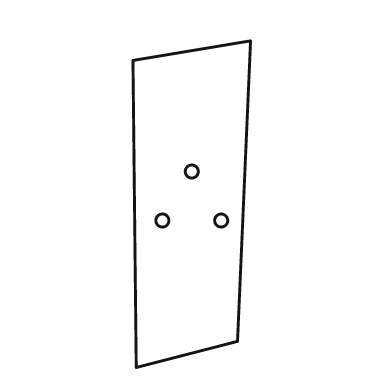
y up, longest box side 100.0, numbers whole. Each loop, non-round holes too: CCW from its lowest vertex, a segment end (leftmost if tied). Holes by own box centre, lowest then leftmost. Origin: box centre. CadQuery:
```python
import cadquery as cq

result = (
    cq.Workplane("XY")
    .moveTo(-17.0, -50.0)
    .lineTo(14.0, -42.0)
    .lineTo(18.0, 50.0)
    .lineTo(-18.0, 44.0)
    .close()
    .moveTo(-9.0, -5.0)
    .circle(2.0)
    .moveTo(9.0, -5.0)
    .circle(2.0)
    .moveTo(0.0, 10.0)
    .circle(2.0)
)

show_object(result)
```